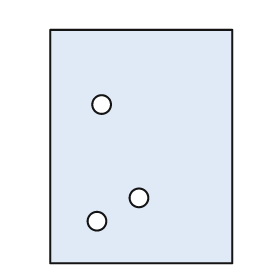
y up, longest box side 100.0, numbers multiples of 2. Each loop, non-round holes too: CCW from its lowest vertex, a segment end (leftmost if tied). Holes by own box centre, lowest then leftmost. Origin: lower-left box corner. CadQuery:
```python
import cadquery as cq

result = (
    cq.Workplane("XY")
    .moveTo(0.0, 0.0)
    .lineTo(78.0, 0.0)
    .lineTo(78.0, 100.0)
    .lineTo(0.0, 100.0)
    .close()
    .moveTo(20.0, 18.0)
    .circle(4.0)
    .moveTo(38.0, 28.0)
    .circle(4.0)
    .moveTo(22.0, 68.0)
    .circle(4.0)
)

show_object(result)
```